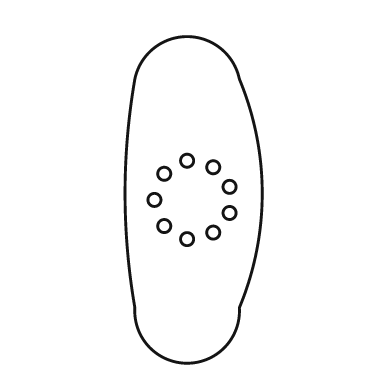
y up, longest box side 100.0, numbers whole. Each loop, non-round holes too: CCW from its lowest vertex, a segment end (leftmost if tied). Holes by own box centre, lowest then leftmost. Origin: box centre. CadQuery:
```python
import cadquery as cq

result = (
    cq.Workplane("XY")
    .moveTo(-18.0, -33.0)
    .threePointArc((-2.0, -50.0), (14.0, -33.0))
    .threePointArc((21.0, 2.0), (14.0, 37.0))
    .threePointArc((-2.0, 50.0), (-18.0, 37.0))
    .threePointArc((-21.0, 2.0), (-18.0, -33.0))
    .close()
    .moveTo(-2.0, -12.0)
    .circle(2.0)
    .moveTo(6.0, -10.0)
    .circle(2.0)
    .moveTo(-9.0, -8.0)
    .circle(2.0)
    .moveTo(11.0, -4.0)
    .circle(2.0)
    .moveTo(-12.0, 0.0)
    .circle(2.0)
    .moveTo(11.0, 4.0)
    .circle(2.0)
    .moveTo(-9.0, 8.0)
    .circle(2.0)
    .moveTo(6.0, 10.0)
    .circle(2.0)
    .moveTo(-2.0, 12.0)
    .circle(2.0)
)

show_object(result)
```